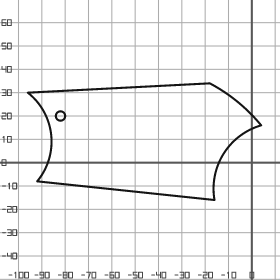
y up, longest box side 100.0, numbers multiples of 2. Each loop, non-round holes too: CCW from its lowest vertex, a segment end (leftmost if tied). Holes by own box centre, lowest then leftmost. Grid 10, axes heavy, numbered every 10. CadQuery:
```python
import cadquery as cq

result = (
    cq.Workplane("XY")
    .moveTo(-16.0, -16.0)
    .threePointArc((-12.0, 4.0), (4.0, 16.0))
    .threePointArc((-6.0, 26.0), (-18.0, 34.0))
    .lineTo(-96.0, 30.0)
    .threePointArc((-86.0, 12.0), (-92.0, -8.0))
    .close()
    .moveTo(-82.0, 20.0)
    .circle(2.0)
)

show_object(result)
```